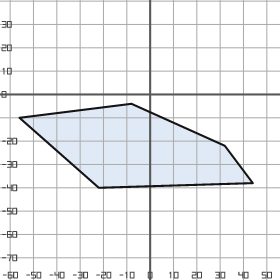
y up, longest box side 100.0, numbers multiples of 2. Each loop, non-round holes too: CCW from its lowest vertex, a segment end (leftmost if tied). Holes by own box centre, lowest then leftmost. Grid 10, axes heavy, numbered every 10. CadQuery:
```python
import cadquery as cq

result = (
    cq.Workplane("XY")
    .moveTo(-22.0, -40.0)
    .lineTo(44.0, -38.0)
    .lineTo(32.0, -22.0)
    .lineTo(-8.0, -4.0)
    .lineTo(-56.0, -10.0)
    .close()
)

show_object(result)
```